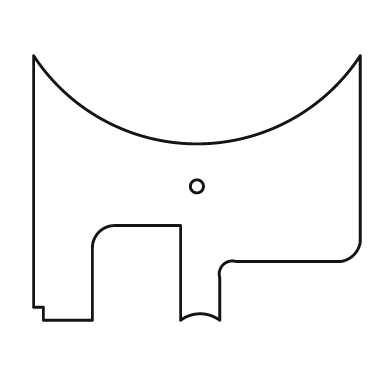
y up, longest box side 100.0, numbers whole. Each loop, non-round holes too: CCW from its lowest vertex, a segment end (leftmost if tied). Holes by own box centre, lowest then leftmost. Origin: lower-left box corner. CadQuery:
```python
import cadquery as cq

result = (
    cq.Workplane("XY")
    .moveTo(3.0, 0.0)
    .lineTo(18.0, 0.0)
    .lineTo(18.0, 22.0)
    .threePointArc((20.0, 27.0), (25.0, 29.0))
    .lineTo(45.0, 29.0)
    .lineTo(45.0, 0.0)
    .threePointArc((51.0, 2.0), (57.0, 0.0))
    .lineTo(57.0, 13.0)
    .threePointArc((58.0, 17.0), (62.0, 18.0))
    .lineTo(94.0, 18.0)
    .threePointArc((98.0, 20.0), (100.0, 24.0))
    .lineTo(100.0, 81.0)
    .threePointArc((50.0, 54.0), (0.0, 81.0))
    .lineTo(0.0, 4.0)
    .lineTo(3.0, 4.0)
    .close()
    .moveTo(50.0, 41.0)
    .circle(2.0)
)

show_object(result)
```